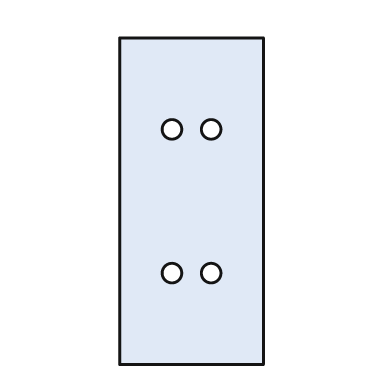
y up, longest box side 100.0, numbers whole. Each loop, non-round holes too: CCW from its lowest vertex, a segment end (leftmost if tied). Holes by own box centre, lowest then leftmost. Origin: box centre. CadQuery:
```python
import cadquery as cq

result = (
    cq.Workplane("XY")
    .moveTo(-22.0, -50.0)
    .lineTo(22.0, -50.0)
    .lineTo(22.0, 50.0)
    .lineTo(-22.0, 50.0)
    .close()
    .moveTo(-6.0, -22.0)
    .circle(3.0)
    .moveTo(6.0, -22.0)
    .circle(3.0)
    .moveTo(-6.0, 22.0)
    .circle(3.0)
    .moveTo(6.0, 22.0)
    .circle(3.0)
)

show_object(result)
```